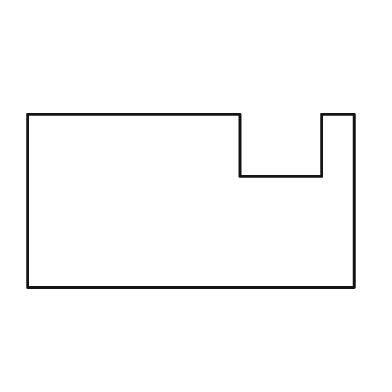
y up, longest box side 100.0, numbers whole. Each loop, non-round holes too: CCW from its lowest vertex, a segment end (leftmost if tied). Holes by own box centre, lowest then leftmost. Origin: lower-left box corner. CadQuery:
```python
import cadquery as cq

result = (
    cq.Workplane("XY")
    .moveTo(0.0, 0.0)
    .lineTo(100.0, 0.0)
    .lineTo(100.0, 53.0)
    .lineTo(90.0, 53.0)
    .lineTo(90.0, 34.0)
    .lineTo(65.0, 34.0)
    .lineTo(65.0, 53.0)
    .lineTo(0.0, 53.0)
    .close()
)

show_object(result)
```